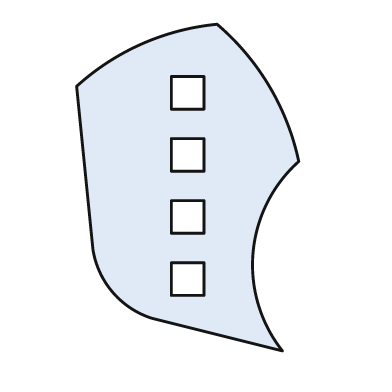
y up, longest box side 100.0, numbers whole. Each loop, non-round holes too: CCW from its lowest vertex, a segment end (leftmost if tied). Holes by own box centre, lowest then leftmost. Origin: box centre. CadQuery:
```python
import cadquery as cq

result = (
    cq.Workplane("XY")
    .moveTo(29.0, -50.0)
    .threePointArc((20.0, -20.0), (34.0, 8.0))
    .threePointArc((25.0, 31.0), (9.0, 50.0))
    .threePointArc((-14.0, 44.0), (-34.0, 31.0))
    .lineTo(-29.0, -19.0)
    .threePointArc((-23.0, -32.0), (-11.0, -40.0))
    .close()
    .moveTo(-5.0, -33.0)
    .lineTo(5.0, -33.0)
    .lineTo(5.0, -23.0)
    .lineTo(-5.0, -23.0)
    .close()
    .moveTo(-5.0, -14.0)
    .lineTo(5.0, -14.0)
    .lineTo(5.0, -4.0)
    .lineTo(-5.0, -4.0)
    .close()
    .moveTo(-5.0, 5.0)
    .lineTo(5.0, 5.0)
    .lineTo(5.0, 15.0)
    .lineTo(-5.0, 15.0)
    .close()
    .moveTo(-5.0, 24.0)
    .lineTo(5.0, 24.0)
    .lineTo(5.0, 34.0)
    .lineTo(-5.0, 34.0)
    .close()
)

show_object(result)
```